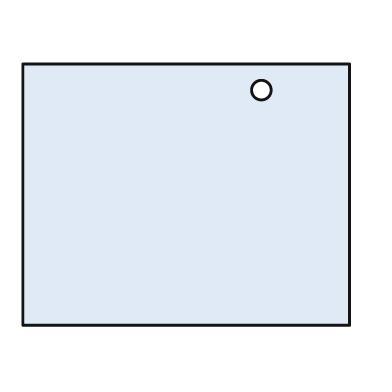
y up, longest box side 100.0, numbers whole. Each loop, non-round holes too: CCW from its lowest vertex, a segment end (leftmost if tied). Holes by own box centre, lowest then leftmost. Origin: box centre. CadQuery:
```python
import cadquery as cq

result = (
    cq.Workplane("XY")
    .moveTo(-50.0, -40.0)
    .lineTo(50.0, -40.0)
    .lineTo(50.0, 40.0)
    .lineTo(-50.0, 40.0)
    .close()
    .moveTo(23.0, 32.0)
    .circle(3.0)
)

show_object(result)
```